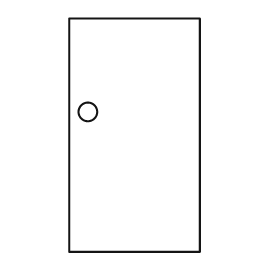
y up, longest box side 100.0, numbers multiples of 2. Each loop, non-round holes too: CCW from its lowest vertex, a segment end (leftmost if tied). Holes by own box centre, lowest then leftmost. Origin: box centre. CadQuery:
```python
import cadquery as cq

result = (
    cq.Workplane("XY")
    .moveTo(-28.0, -50.0)
    .lineTo(28.0, -50.0)
    .lineTo(28.0, 50.0)
    .lineTo(-28.0, 50.0)
    .close()
    .moveTo(-20.0, 10.0)
    .circle(4.0)
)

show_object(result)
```